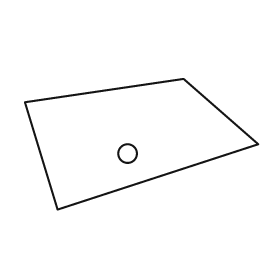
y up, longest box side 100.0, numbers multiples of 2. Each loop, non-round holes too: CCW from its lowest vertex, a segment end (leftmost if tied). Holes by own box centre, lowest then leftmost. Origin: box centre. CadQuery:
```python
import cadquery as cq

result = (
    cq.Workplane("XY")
    .moveTo(-36.0, -28.0)
    .lineTo(50.0, 0.0)
    .lineTo(18.0, 28.0)
    .lineTo(-50.0, 18.0)
    .close()
    .moveTo(-6.0, -4.0)
    .circle(4.0)
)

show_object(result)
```